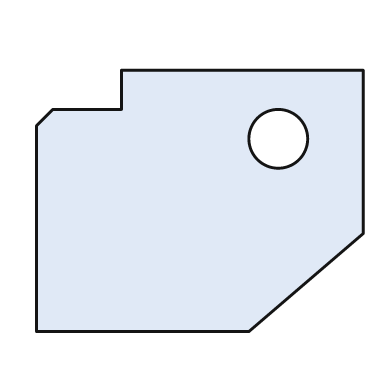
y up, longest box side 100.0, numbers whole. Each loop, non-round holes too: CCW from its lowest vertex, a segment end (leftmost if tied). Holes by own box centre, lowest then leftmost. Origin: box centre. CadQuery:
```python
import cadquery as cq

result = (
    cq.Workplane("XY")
    .moveTo(-50.0, -40.0)
    .lineTo(15.0, -40.0)
    .lineTo(50.0, -10.0)
    .lineTo(50.0, 40.0)
    .lineTo(-24.0, 40.0)
    .lineTo(-24.0, 28.0)
    .lineTo(-45.0, 28.0)
    .lineTo(-50.0, 23.0)
    .close()
    .moveTo(24.0, 19.0)
    .circle(9.0)
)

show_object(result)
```